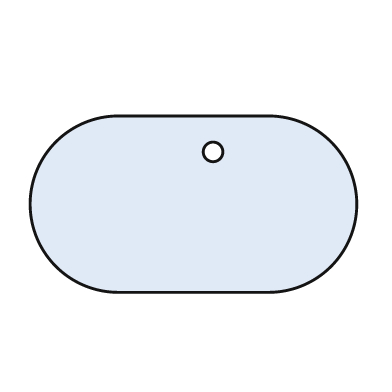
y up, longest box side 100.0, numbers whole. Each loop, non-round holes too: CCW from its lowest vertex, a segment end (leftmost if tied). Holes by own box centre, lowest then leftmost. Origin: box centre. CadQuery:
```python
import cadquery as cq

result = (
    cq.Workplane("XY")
    .moveTo(-23.0, -27.0)
    .lineTo(23.0, -27.0)
    .threePointArc((50.0, 0.0), (23.0, 27.0))
    .lineTo(-23.0, 27.0)
    .threePointArc((-50.0, 0.0), (-23.0, -27.0))
    .close()
    .moveTo(6.0, 16.0)
    .circle(3.0)
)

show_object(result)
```